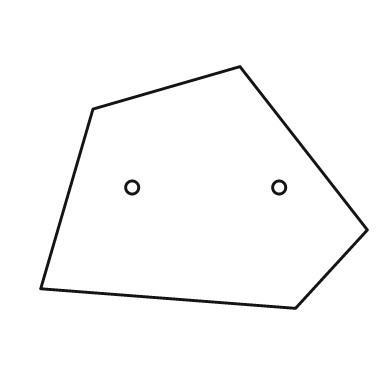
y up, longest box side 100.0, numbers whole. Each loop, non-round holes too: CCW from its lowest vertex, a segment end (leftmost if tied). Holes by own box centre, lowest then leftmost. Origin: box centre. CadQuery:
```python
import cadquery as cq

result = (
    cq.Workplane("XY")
    .moveTo(28.0, -37.0)
    .lineTo(50.0, -13.0)
    .lineTo(11.0, 37.0)
    .lineTo(-34.0, 24.0)
    .lineTo(-50.0, -31.0)
    .close()
    .moveTo(-22.0, 0.0)
    .circle(2.0)
    .moveTo(23.0, 0.0)
    .circle(2.0)
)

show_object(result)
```